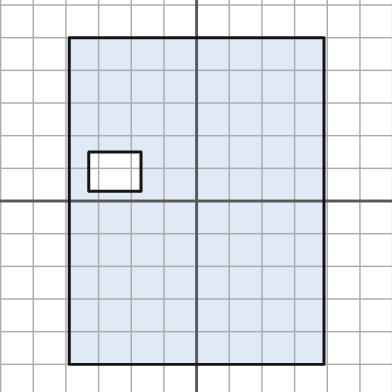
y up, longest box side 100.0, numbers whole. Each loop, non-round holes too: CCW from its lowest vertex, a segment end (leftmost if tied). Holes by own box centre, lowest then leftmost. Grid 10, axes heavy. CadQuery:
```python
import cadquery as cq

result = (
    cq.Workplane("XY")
    .moveTo(-39.0, -50.0)
    .lineTo(39.0, -50.0)
    .lineTo(39.0, 50.0)
    .lineTo(-39.0, 50.0)
    .close()
    .moveTo(-33.0, 3.0)
    .lineTo(-17.0, 3.0)
    .lineTo(-17.0, 15.0)
    .lineTo(-33.0, 15.0)
    .close()
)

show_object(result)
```